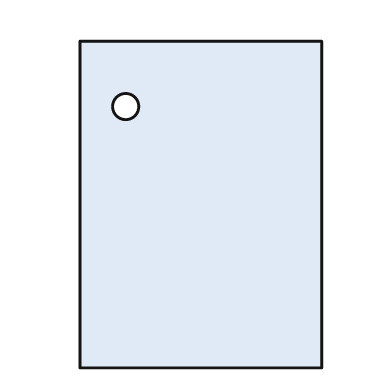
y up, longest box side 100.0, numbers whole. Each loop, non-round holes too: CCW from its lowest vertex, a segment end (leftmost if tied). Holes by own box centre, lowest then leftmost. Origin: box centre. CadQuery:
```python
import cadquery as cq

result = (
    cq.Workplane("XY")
    .moveTo(-37.0, -50.0)
    .lineTo(37.0, -50.0)
    .lineTo(37.0, 50.0)
    .lineTo(-37.0, 50.0)
    .close()
    .moveTo(-23.0, 30.0)
    .circle(4.0)
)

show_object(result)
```